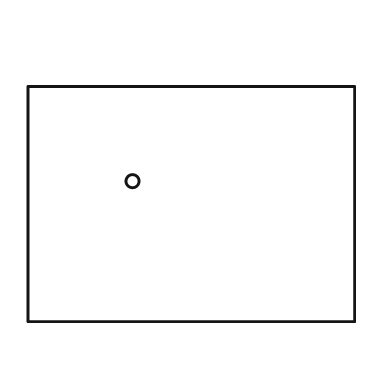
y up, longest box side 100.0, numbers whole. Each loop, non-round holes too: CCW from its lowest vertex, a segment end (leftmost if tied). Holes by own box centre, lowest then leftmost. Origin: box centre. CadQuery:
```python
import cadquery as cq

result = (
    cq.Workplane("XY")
    .moveTo(-50.0, -36.0)
    .lineTo(50.0, -36.0)
    .lineTo(50.0, 36.0)
    .lineTo(-50.0, 36.0)
    .close()
    .moveTo(-18.0, 7.0)
    .circle(2.0)
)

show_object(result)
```